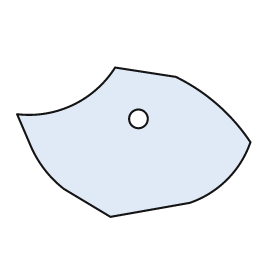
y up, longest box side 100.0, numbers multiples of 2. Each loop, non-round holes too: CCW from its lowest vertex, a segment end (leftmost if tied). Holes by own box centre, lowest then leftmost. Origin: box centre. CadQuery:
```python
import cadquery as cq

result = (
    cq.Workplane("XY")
    .moveTo(-10.0, -32.0)
    .lineTo(24.0, -26.0)
    .threePointArc((40.0, -16.0), (50.0, 0.0))
    .threePointArc((36.0, 16.0), (18.0, 28.0))
    .lineTo(-8.0, 32.0)
    .threePointArc((-26.0, 16.0), (-50.0, 12.0))
    .lineTo(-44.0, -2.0)
    .threePointArc((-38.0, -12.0), (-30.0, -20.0))
    .close()
    .moveTo(2.0, 10.0)
    .circle(4.0)
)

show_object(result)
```